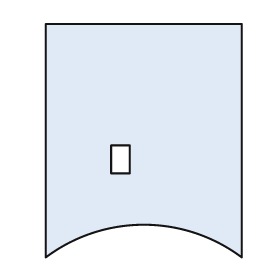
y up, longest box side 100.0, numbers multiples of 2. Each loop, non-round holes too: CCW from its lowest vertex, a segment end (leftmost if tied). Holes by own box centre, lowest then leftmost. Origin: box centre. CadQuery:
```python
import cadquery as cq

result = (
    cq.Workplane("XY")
    .moveTo(-42.0, -50.0)
    .threePointArc((0.0, -36.0), (42.0, -50.0))
    .lineTo(42.0, 50.0)
    .lineTo(-42.0, 50.0)
    .close()
    .moveTo(-14.0, -14.0)
    .lineTo(-6.0, -14.0)
    .lineTo(-6.0, -2.0)
    .lineTo(-14.0, -2.0)
    .close()
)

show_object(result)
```